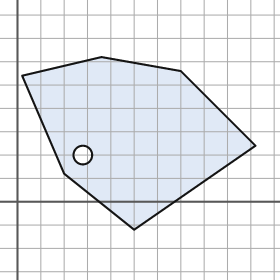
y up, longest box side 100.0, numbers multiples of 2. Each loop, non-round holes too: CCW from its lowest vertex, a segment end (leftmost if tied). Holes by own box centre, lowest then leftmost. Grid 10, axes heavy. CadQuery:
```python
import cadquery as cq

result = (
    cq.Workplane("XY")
    .moveTo(50.0, -12.0)
    .lineTo(102.0, 24.0)
    .lineTo(70.0, 56.0)
    .lineTo(36.0, 62.0)
    .lineTo(2.0, 54.0)
    .lineTo(20.0, 12.0)
    .close()
    .moveTo(28.0, 20.0)
    .circle(4.0)
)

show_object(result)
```